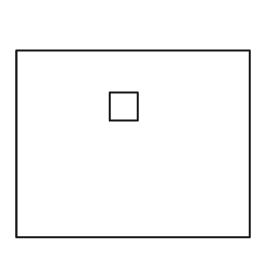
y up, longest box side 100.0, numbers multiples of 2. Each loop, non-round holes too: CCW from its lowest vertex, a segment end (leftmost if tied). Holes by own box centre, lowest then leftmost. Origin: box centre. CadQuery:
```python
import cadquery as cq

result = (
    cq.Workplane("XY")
    .moveTo(-50.0, -40.0)
    .lineTo(50.0, -40.0)
    .lineTo(50.0, 40.0)
    .lineTo(-50.0, 40.0)
    .close()
    .moveTo(-10.0, 10.0)
    .lineTo(2.0, 10.0)
    .lineTo(2.0, 22.0)
    .lineTo(-10.0, 22.0)
    .close()
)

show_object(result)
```